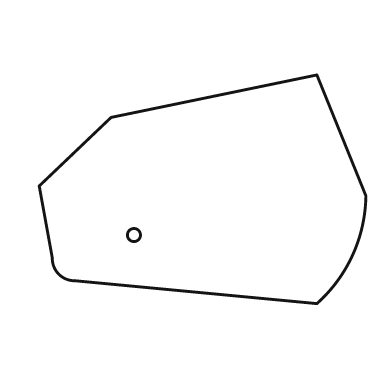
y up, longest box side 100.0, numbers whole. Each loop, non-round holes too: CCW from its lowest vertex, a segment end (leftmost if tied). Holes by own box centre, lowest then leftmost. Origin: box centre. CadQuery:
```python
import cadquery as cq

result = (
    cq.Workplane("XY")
    .moveTo(35.0, -35.0)
    .threePointArc((46.0, -20.0), (50.0, -2.0))
    .lineTo(35.0, 35.0)
    .lineTo(-28.0, 22.0)
    .lineTo(-50.0, 1.0)
    .lineTo(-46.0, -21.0)
    .threePointArc((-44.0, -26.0), (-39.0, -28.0))
    .close()
    .moveTo(-21.0, -14.0)
    .circle(2.0)
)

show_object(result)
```